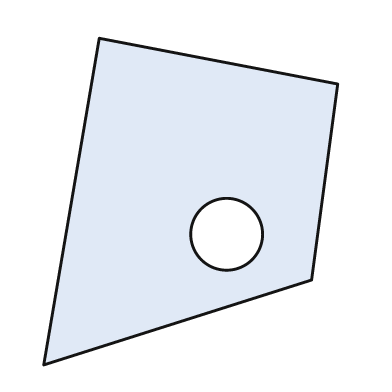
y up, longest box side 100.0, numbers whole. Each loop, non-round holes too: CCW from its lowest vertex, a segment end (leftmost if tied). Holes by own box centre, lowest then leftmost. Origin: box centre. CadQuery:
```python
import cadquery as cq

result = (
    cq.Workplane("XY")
    .moveTo(-45.0, -50.0)
    .lineTo(37.0, -24.0)
    .lineTo(45.0, 36.0)
    .lineTo(-28.0, 50.0)
    .close()
    .moveTo(11.0, -10.0)
    .circle(11.0)
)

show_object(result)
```